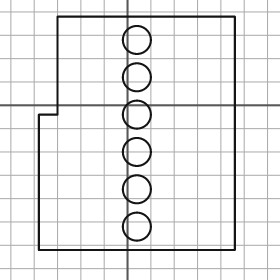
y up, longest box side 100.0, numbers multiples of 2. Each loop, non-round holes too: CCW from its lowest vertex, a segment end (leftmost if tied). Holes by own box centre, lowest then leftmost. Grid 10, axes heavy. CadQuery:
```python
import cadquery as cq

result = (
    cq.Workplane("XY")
    .moveTo(-38.0, -62.0)
    .lineTo(46.0, -62.0)
    .lineTo(46.0, 38.0)
    .lineTo(-30.0, 38.0)
    .lineTo(-30.0, -4.0)
    .lineTo(-38.0, -4.0)
    .close()
    .moveTo(4.0, -52.0)
    .circle(6.0)
    .moveTo(4.0, -36.0)
    .circle(6.0)
    .moveTo(4.0, -20.0)
    .circle(6.0)
    .moveTo(4.0, -4.0)
    .circle(6.0)
    .moveTo(4.0, 12.0)
    .circle(6.0)
    .moveTo(4.0, 28.0)
    .circle(6.0)
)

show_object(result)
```